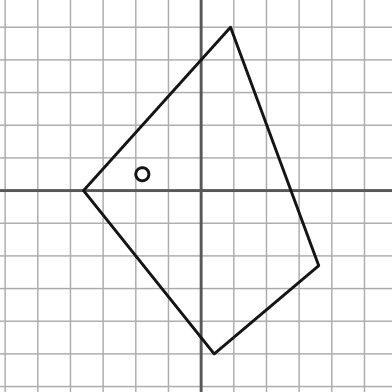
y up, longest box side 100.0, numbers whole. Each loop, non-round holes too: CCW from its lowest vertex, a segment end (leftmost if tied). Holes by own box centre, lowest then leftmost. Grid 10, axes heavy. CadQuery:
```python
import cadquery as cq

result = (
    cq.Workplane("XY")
    .moveTo(4.0, -50.0)
    .lineTo(36.0, -23.0)
    .lineTo(9.0, 50.0)
    .lineTo(-36.0, 0.0)
    .close()
    .moveTo(-18.0, 5.0)
    .circle(2.0)
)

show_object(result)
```